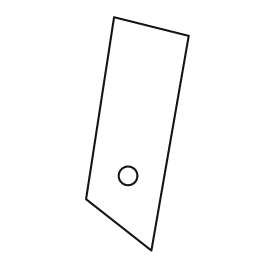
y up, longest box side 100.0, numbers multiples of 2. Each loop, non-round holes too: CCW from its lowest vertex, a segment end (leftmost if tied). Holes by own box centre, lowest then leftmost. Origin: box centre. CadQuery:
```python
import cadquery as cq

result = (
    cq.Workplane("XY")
    .moveTo(6.0, -50.0)
    .lineTo(22.0, 42.0)
    .lineTo(-10.0, 50.0)
    .lineTo(-22.0, -28.0)
    .close()
    .moveTo(-4.0, -18.0)
    .circle(4.0)
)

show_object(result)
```